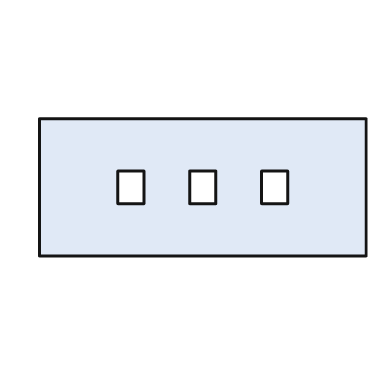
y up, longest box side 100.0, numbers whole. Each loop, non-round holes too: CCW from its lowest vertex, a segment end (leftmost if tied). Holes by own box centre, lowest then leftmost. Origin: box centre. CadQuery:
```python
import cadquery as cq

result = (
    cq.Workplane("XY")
    .moveTo(-50.0, -21.0)
    .lineTo(50.0, -21.0)
    .lineTo(50.0, 21.0)
    .lineTo(-50.0, 21.0)
    .close()
    .moveTo(-26.0, -5.0)
    .lineTo(-18.0, -5.0)
    .lineTo(-18.0, 5.0)
    .lineTo(-26.0, 5.0)
    .close()
    .moveTo(-4.0, -5.0)
    .lineTo(4.0, -5.0)
    .lineTo(4.0, 5.0)
    .lineTo(-4.0, 5.0)
    .close()
    .moveTo(18.0, -5.0)
    .lineTo(26.0, -5.0)
    .lineTo(26.0, 5.0)
    .lineTo(18.0, 5.0)
    .close()
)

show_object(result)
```